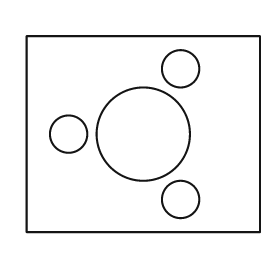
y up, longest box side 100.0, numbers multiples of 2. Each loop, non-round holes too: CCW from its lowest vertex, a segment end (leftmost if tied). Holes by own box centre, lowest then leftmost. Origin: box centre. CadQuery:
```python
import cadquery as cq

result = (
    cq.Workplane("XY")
    .moveTo(-50.0, -42.0)
    .lineTo(50.0, -42.0)
    .lineTo(50.0, 42.0)
    .lineTo(-50.0, 42.0)
    .close()
    .moveTo(16.0, -28.0)
    .circle(8.0)
    .moveTo(-32.0, 0.0)
    .circle(8.0)
    .moveTo(0.0, 0.0)
    .circle(20.0)
    .moveTo(16.0, 28.0)
    .circle(8.0)
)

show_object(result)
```